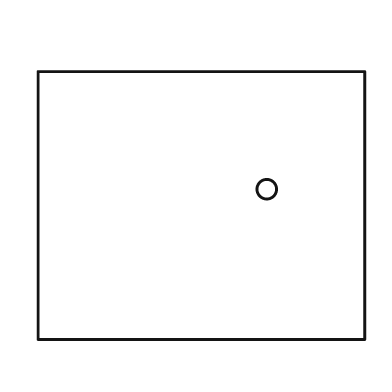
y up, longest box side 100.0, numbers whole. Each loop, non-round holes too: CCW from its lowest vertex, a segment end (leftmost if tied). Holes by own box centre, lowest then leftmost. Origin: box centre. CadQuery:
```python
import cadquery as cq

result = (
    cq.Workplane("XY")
    .moveTo(-50.0, -41.0)
    .lineTo(50.0, -41.0)
    .lineTo(50.0, 41.0)
    .lineTo(-50.0, 41.0)
    .close()
    .moveTo(20.0, 5.0)
    .circle(3.0)
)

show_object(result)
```